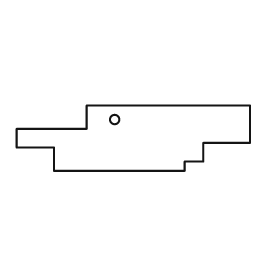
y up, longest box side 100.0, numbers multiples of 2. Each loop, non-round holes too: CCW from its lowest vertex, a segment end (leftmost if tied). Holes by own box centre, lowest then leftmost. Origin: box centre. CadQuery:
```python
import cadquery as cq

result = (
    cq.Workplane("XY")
    .moveTo(-34.0, -14.0)
    .lineTo(22.0, -14.0)
    .lineTo(22.0, -10.0)
    .lineTo(30.0, -10.0)
    .lineTo(30.0, -2.0)
    .lineTo(50.0, -2.0)
    .lineTo(50.0, 14.0)
    .lineTo(-20.0, 14.0)
    .lineTo(-20.0, 4.0)
    .lineTo(-50.0, 4.0)
    .lineTo(-50.0, -4.0)
    .lineTo(-34.0, -4.0)
    .close()
    .moveTo(-8.0, 8.0)
    .circle(2.0)
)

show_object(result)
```